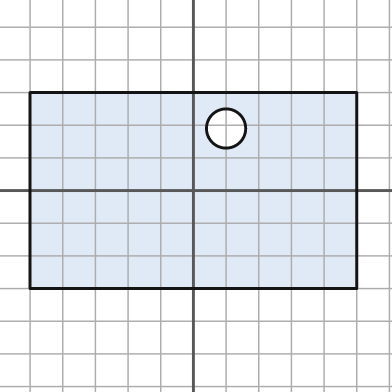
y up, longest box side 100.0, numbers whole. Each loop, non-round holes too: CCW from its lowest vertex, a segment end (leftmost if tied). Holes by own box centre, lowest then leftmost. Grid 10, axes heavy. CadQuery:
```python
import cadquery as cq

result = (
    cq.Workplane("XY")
    .moveTo(-50.0, -30.0)
    .lineTo(50.0, -30.0)
    .lineTo(50.0, 30.0)
    .lineTo(-50.0, 30.0)
    .close()
    .moveTo(10.0, 19.0)
    .circle(6.0)
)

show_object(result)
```